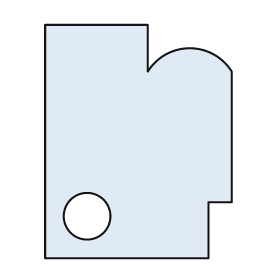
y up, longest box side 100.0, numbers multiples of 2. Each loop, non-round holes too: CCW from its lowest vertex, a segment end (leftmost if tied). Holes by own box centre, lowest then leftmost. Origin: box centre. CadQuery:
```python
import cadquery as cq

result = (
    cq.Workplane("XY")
    .moveTo(-40.0, -50.0)
    .lineTo(30.0, -50.0)
    .lineTo(30.0, -26.0)
    .lineTo(40.0, -26.0)
    .lineTo(40.0, 30.0)
    .threePointArc((22.0, 40.0), (4.0, 30.0))
    .lineTo(4.0, 50.0)
    .lineTo(-40.0, 50.0)
    .close()
    .moveTo(-22.0, -32.0)
    .circle(10.0)
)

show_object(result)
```